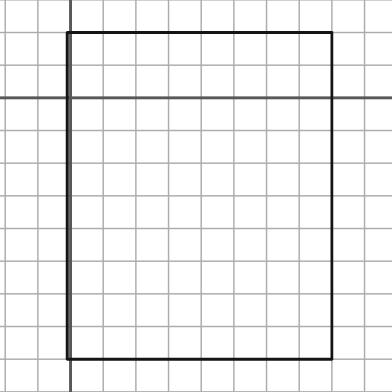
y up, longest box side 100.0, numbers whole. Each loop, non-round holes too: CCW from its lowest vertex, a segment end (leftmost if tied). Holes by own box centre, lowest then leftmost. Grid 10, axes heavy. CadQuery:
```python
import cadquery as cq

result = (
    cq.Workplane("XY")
    .moveTo(-1.0, -80.0)
    .lineTo(80.0, -80.0)
    .lineTo(80.0, 20.0)
    .lineTo(-1.0, 20.0)
    .close()
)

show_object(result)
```